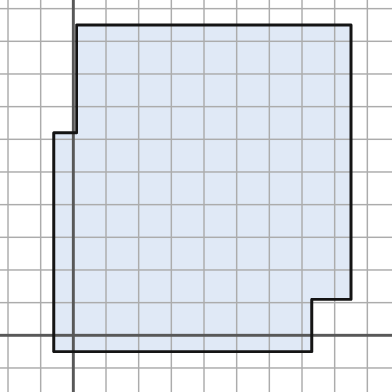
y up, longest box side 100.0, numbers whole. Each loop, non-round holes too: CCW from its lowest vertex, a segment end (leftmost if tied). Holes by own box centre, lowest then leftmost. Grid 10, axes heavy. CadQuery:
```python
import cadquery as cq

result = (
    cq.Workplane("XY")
    .moveTo(-6.0, -5.0)
    .lineTo(73.0, -5.0)
    .lineTo(73.0, 11.0)
    .lineTo(85.0, 11.0)
    .lineTo(85.0, 95.0)
    .lineTo(1.0, 95.0)
    .lineTo(1.0, 62.0)
    .lineTo(-6.0, 62.0)
    .close()
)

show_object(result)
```